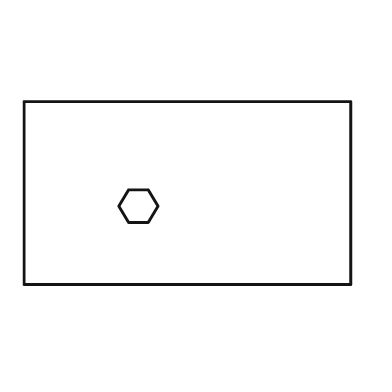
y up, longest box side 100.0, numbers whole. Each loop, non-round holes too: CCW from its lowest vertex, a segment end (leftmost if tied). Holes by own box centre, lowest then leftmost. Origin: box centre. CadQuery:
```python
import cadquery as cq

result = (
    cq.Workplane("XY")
    .moveTo(-50.0, -28.0)
    .lineTo(50.0, -28.0)
    .lineTo(50.0, 28.0)
    .lineTo(-50.0, 28.0)
    .close()
    .moveTo(-18.0, -9.0)
    .lineTo(-12.0, -9.0)
    .lineTo(-9.0, -4.0)
    .lineTo(-12.0, 1.0)
    .lineTo(-18.0, 1.0)
    .lineTo(-21.0, -4.0)
    .close()
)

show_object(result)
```